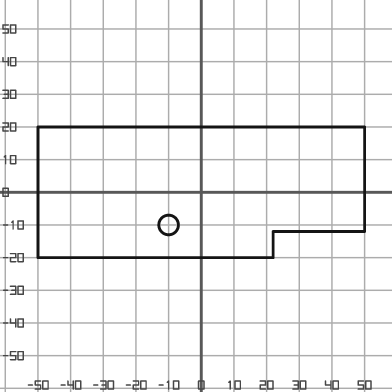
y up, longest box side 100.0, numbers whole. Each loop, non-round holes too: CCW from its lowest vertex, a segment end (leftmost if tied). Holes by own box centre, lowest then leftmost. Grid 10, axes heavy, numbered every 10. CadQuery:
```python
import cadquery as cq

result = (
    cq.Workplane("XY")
    .moveTo(-50.0, -20.0)
    .lineTo(22.0, -20.0)
    .lineTo(22.0, -12.0)
    .lineTo(50.0, -12.0)
    .lineTo(50.0, 20.0)
    .lineTo(-50.0, 20.0)
    .close()
    .moveTo(-10.0, -10.0)
    .circle(3.0)
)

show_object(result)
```